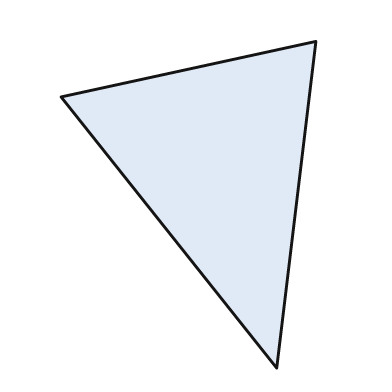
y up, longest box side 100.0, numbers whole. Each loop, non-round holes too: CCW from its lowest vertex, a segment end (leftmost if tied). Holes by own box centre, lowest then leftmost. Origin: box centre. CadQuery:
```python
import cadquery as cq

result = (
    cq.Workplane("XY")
    .moveTo(27.0, -50.0)
    .lineTo(39.0, 50.0)
    .lineTo(-39.0, 33.0)
    .close()
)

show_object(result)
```